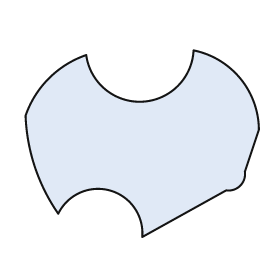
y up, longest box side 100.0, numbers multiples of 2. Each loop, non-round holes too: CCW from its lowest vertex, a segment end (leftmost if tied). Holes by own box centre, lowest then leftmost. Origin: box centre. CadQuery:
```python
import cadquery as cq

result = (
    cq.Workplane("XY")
    .moveTo(0.0, -40.0)
    .lineTo(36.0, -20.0)
    .threePointArc((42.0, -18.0), (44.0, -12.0))
    .lineTo(50.0, 6.0)
    .threePointArc((42.0, 28.0), (22.0, 40.0))
    .threePointArc((0.0, 18.0), (-24.0, 38.0))
    .threePointArc((-40.0, 28.0), (-50.0, 12.0))
    .threePointArc((-46.0, -10.0), (-36.0, -30.0))
    .threePointArc((-14.0, -20.0), (0.0, -40.0))
    .close()
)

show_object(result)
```